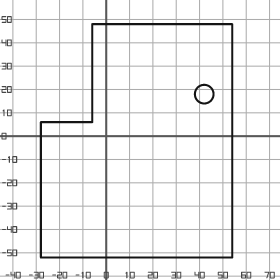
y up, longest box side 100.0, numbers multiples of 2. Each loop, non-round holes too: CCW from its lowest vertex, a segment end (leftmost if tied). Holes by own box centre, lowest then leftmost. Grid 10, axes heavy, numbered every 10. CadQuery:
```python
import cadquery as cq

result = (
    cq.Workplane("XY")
    .moveTo(-28.0, -52.0)
    .lineTo(54.0, -52.0)
    .lineTo(54.0, 48.0)
    .lineTo(-6.0, 48.0)
    .lineTo(-6.0, 6.0)
    .lineTo(-28.0, 6.0)
    .close()
    .moveTo(42.0, 18.0)
    .circle(4.0)
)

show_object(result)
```